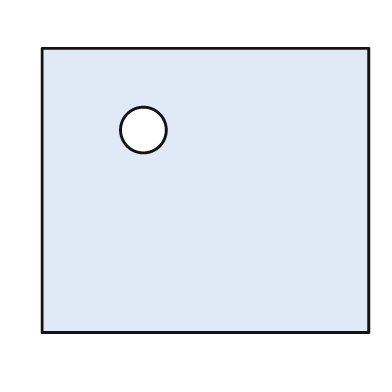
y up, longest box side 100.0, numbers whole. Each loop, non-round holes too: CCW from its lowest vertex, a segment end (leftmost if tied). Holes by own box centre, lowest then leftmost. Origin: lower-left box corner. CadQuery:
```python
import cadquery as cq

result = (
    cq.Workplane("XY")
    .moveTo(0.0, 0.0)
    .lineTo(100.0, 0.0)
    .lineTo(100.0, 87.0)
    .lineTo(0.0, 87.0)
    .close()
    .moveTo(31.0, 62.0)
    .circle(7.0)
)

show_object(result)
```